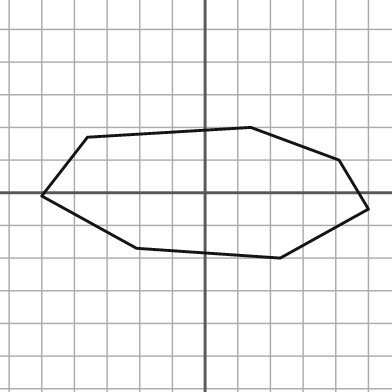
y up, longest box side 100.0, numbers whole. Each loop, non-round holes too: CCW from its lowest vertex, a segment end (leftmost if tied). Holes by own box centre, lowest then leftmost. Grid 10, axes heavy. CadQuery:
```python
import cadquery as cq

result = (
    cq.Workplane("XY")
    .moveTo(23.0, -20.0)
    .lineTo(50.0, -5.0)
    .lineTo(41.0, 10.0)
    .lineTo(14.0, 20.0)
    .lineTo(-36.0, 17.0)
    .lineTo(-50.0, -1.0)
    .lineTo(-21.0, -17.0)
    .close()
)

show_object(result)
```